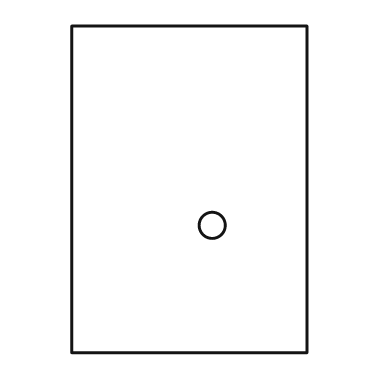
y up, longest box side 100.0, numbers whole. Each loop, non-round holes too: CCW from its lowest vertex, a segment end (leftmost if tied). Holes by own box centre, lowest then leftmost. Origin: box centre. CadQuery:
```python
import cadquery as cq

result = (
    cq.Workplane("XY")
    .moveTo(-36.0, -50.0)
    .lineTo(36.0, -50.0)
    .lineTo(36.0, 50.0)
    .lineTo(-36.0, 50.0)
    .close()
    .moveTo(7.0, -11.0)
    .circle(4.0)
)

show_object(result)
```